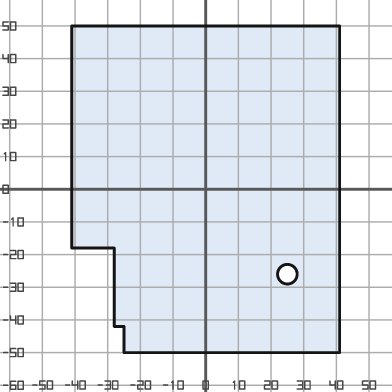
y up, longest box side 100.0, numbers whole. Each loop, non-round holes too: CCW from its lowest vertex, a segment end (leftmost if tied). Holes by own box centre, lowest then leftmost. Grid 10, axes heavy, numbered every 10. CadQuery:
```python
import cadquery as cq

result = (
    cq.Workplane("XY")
    .moveTo(-25.0, -50.0)
    .lineTo(41.0, -50.0)
    .lineTo(41.0, 50.0)
    .lineTo(-41.0, 50.0)
    .lineTo(-41.0, -18.0)
    .lineTo(-28.0, -18.0)
    .lineTo(-28.0, -42.0)
    .lineTo(-25.0, -42.0)
    .close()
    .moveTo(25.0, -26.0)
    .circle(3.0)
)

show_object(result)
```